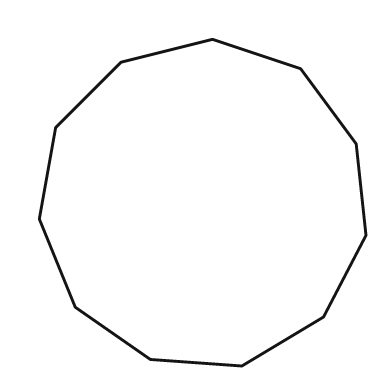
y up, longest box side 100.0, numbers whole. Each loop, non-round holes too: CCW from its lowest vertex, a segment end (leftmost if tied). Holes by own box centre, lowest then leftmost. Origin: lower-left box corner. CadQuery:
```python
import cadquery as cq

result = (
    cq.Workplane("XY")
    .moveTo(62.0, 0.0)
    .lineTo(87.0, 15.0)
    .lineTo(100.0, 40.0)
    .lineTo(97.0, 68.0)
    .lineTo(80.0, 91.0)
    .lineTo(53.0, 100.0)
    .lineTo(25.0, 93.0)
    .lineTo(5.0, 73.0)
    .lineTo(0.0, 45.0)
    .lineTo(11.0, 18.0)
    .lineTo(34.0, 2.0)
    .close()
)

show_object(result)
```